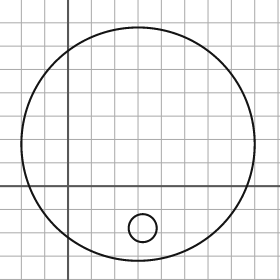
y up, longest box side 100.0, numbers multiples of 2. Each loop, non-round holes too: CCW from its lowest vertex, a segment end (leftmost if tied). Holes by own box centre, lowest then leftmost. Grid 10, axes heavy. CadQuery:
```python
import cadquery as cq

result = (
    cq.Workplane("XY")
    .moveTo(30.0, 18.0)
    .circle(50.0)
    .moveTo(32.0, -18.0)
    .circle(6.0)
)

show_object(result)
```